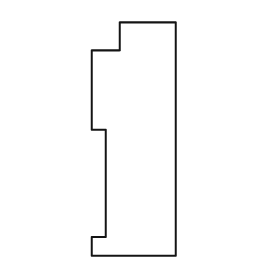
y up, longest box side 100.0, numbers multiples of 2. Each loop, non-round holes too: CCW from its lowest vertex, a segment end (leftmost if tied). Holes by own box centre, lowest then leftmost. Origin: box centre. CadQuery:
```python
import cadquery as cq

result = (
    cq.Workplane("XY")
    .moveTo(-18.0, -50.0)
    .lineTo(18.0, -50.0)
    .lineTo(18.0, 50.0)
    .lineTo(-6.0, 50.0)
    .lineTo(-6.0, 38.0)
    .lineTo(-18.0, 38.0)
    .lineTo(-18.0, 4.0)
    .lineTo(-12.0, 4.0)
    .lineTo(-12.0, -42.0)
    .lineTo(-18.0, -42.0)
    .close()
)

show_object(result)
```